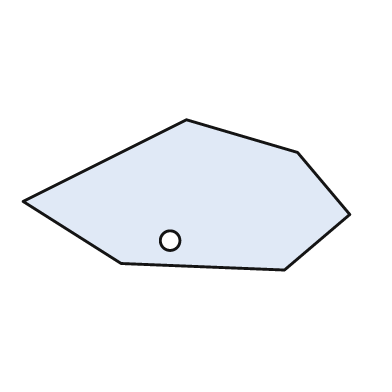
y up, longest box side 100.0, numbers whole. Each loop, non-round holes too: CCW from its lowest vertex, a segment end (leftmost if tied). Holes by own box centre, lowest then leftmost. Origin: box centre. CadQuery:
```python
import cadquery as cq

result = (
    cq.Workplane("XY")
    .moveTo(30.0, -23.0)
    .lineTo(50.0, -6.0)
    .lineTo(34.0, 13.0)
    .lineTo(0.0, 23.0)
    .lineTo(-50.0, -2.0)
    .lineTo(-20.0, -21.0)
    .close()
    .moveTo(-5.0, -14.0)
    .circle(3.0)
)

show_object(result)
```